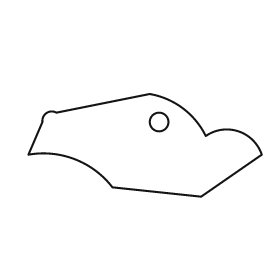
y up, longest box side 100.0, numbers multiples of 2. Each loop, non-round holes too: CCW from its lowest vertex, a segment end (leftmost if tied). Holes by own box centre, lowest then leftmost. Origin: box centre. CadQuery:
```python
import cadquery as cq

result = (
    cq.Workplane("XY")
    .moveTo(24.0, -22.0)
    .lineTo(50.0, -4.0)
    .threePointArc((40.0, 6.0), (26.0, 4.0))
    .threePointArc((16.0, 16.0), (2.0, 22.0))
    .lineTo(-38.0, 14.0)
    .threePointArc((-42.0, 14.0), (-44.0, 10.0))
    .lineTo(-50.0, -4.0)
    .threePointArc((-30.0, -6.0), (-14.0, -18.0))
    .close()
    .moveTo(6.0, 10.0)
    .circle(4.0)
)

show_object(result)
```